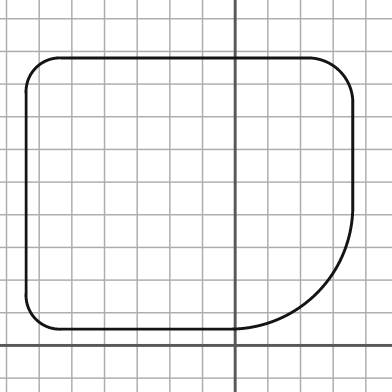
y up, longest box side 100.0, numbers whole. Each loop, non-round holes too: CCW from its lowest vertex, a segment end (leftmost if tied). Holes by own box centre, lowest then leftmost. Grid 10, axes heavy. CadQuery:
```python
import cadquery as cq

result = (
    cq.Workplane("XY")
    .moveTo(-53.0, 5.0)
    .lineTo(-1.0, 5.0)
    .threePointArc((25.0, 16.0), (36.0, 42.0))
    .lineTo(36.0, 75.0)
    .threePointArc((32.0, 84.0), (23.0, 88.0))
    .lineTo(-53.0, 88.0)
    .threePointArc((-61.0, 85.0), (-64.0, 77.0))
    .lineTo(-64.0, 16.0)
    .threePointArc((-61.0, 8.0), (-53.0, 5.0))
    .close()
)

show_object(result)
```